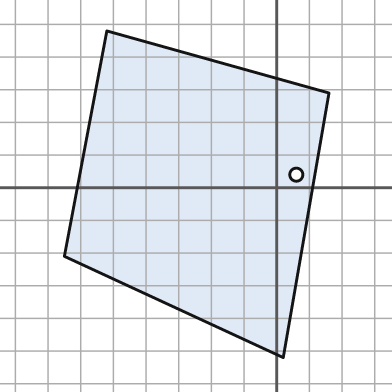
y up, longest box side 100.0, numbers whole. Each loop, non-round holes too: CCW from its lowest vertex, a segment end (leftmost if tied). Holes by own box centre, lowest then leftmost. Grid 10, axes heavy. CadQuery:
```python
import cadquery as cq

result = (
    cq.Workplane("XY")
    .moveTo(2.0, -52.0)
    .lineTo(16.0, 29.0)
    .lineTo(-52.0, 48.0)
    .lineTo(-65.0, -21.0)
    .close()
    .moveTo(6.0, 4.0)
    .circle(2.0)
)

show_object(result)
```